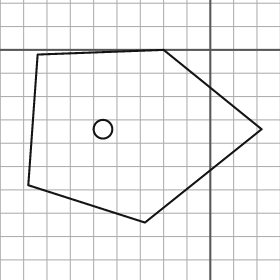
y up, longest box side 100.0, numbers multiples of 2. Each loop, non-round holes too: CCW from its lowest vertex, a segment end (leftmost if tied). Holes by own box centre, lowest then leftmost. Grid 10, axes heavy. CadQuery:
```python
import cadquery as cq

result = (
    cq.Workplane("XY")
    .moveTo(-28.0, -74.0)
    .lineTo(22.0, -34.0)
    .lineTo(-20.0, 0.0)
    .lineTo(-74.0, -2.0)
    .lineTo(-78.0, -58.0)
    .close()
    .moveTo(-46.0, -34.0)
    .circle(4.0)
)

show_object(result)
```